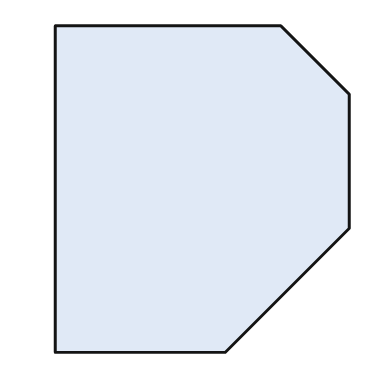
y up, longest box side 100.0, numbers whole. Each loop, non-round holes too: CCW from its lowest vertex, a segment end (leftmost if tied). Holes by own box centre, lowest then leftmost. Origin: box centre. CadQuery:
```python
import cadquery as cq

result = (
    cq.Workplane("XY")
    .moveTo(-45.0, -50.0)
    .lineTo(7.0, -50.0)
    .lineTo(45.0, -12.0)
    .lineTo(45.0, 29.0)
    .lineTo(24.0, 50.0)
    .lineTo(-45.0, 50.0)
    .close()
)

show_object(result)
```